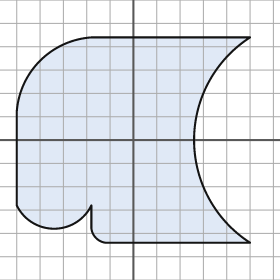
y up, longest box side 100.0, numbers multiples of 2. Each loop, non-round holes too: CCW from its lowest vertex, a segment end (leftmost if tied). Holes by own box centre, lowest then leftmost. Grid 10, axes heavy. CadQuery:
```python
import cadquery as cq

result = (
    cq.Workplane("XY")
    .moveTo(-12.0, -44.0)
    .lineTo(50.0, -44.0)
    .threePointArc((26.0, 0.0), (50.0, 44.0))
    .lineTo(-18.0, 44.0)
    .threePointArc((-40.0, 34.0), (-50.0, 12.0))
    .lineTo(-50.0, -28.0)
    .threePointArc((-34.0, -38.0), (-18.0, -28.0))
    .lineTo(-18.0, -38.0)
    .threePointArc((-16.0, -42.0), (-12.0, -44.0))
    .close()
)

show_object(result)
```